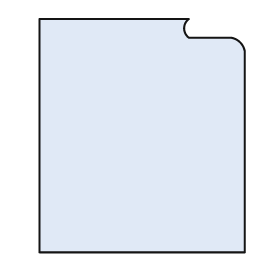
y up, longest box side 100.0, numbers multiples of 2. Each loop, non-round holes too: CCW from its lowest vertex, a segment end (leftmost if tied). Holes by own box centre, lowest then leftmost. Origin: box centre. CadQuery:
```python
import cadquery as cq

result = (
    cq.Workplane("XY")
    .moveTo(-44.0, -50.0)
    .lineTo(44.0, -50.0)
    .lineTo(44.0, 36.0)
    .threePointArc((42.0, 40.0), (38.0, 42.0))
    .lineTo(20.0, 42.0)
    .threePointArc((18.0, 46.0), (20.0, 50.0))
    .lineTo(-44.0, 50.0)
    .close()
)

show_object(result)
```